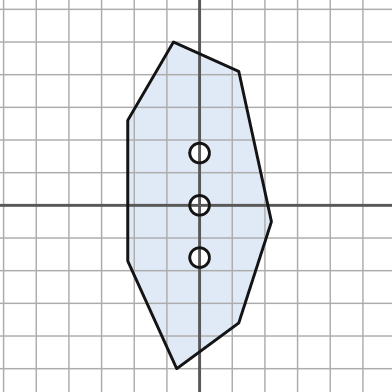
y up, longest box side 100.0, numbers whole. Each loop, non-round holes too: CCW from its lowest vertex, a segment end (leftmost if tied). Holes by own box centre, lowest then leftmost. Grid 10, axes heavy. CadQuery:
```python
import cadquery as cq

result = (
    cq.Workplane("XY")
    .moveTo(-7.0, -50.0)
    .lineTo(12.0, -36.0)
    .lineTo(22.0, -5.0)
    .lineTo(12.0, 41.0)
    .lineTo(-8.0, 50.0)
    .lineTo(-22.0, 26.0)
    .lineTo(-22.0, -17.0)
    .close()
    .moveTo(0.0, -16.0)
    .circle(3.0)
    .moveTo(0.0, 0.0)
    .circle(3.0)
    .moveTo(0.0, 16.0)
    .circle(3.0)
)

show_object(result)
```